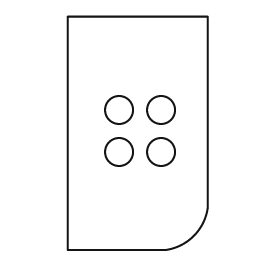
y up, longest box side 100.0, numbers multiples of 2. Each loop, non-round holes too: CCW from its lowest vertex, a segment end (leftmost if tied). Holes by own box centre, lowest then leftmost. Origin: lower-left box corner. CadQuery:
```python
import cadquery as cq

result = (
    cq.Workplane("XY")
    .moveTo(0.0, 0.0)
    .lineTo(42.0, 0.0)
    .threePointArc((54.0, 6.0), (60.0, 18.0))
    .lineTo(60.0, 100.0)
    .lineTo(0.0, 100.0)
    .close()
    .moveTo(22.0, 42.0)
    .circle(6.0)
    .moveTo(40.0, 42.0)
    .circle(6.0)
    .moveTo(22.0, 60.0)
    .circle(6.0)
    .moveTo(40.0, 60.0)
    .circle(6.0)
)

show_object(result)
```